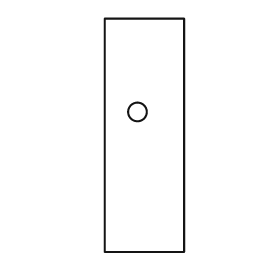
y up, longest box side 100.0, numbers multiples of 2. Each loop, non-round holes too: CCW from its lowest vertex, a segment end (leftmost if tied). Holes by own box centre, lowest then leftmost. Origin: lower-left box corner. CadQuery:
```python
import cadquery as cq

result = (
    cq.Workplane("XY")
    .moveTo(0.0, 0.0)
    .lineTo(34.0, 0.0)
    .lineTo(34.0, 100.0)
    .lineTo(0.0, 100.0)
    .close()
    .moveTo(14.0, 60.0)
    .circle(4.0)
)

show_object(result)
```